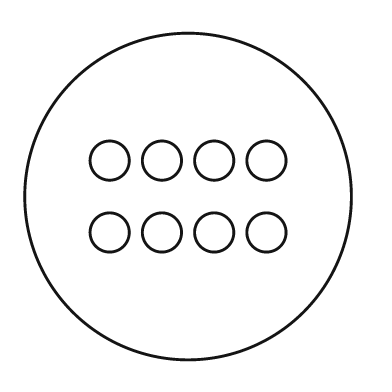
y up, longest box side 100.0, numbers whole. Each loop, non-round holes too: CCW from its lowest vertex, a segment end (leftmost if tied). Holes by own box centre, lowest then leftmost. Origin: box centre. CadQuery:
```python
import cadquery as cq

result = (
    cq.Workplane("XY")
    .moveTo(0.0, 0.0)
    .circle(50.0)
    .moveTo(-24.0, -11.0)
    .circle(6.0)
    .moveTo(-8.0, -11.0)
    .circle(6.0)
    .moveTo(8.0, -11.0)
    .circle(6.0)
    .moveTo(24.0, -11.0)
    .circle(6.0)
    .moveTo(-24.0, 11.0)
    .circle(6.0)
    .moveTo(-8.0, 11.0)
    .circle(6.0)
    .moveTo(8.0, 11.0)
    .circle(6.0)
    .moveTo(24.0, 11.0)
    .circle(6.0)
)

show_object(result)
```